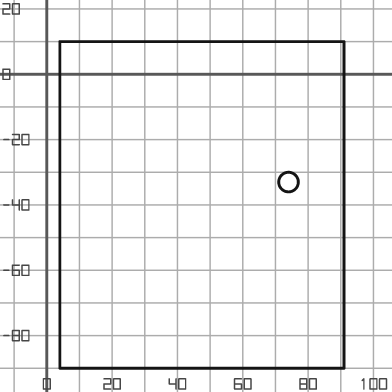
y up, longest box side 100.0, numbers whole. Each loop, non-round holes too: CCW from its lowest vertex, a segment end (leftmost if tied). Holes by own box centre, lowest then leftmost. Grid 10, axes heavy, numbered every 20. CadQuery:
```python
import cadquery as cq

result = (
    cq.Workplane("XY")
    .moveTo(4.0, -90.0)
    .lineTo(91.0, -90.0)
    .lineTo(91.0, 10.0)
    .lineTo(4.0, 10.0)
    .close()
    .moveTo(74.0, -33.0)
    .circle(3.0)
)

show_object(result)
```